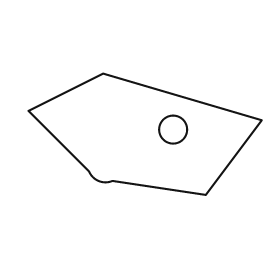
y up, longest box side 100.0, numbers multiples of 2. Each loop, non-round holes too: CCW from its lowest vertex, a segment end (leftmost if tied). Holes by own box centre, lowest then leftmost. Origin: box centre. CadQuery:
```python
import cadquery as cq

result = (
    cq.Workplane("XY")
    .moveTo(26.0, -26.0)
    .lineTo(50.0, 6.0)
    .lineTo(-18.0, 26.0)
    .lineTo(-50.0, 10.0)
    .lineTo(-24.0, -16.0)
    .threePointArc((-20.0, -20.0), (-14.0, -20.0))
    .close()
    .moveTo(12.0, 2.0)
    .circle(6.0)
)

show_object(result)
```